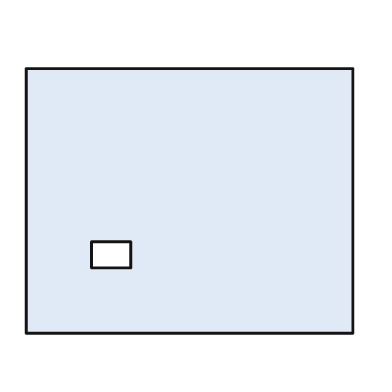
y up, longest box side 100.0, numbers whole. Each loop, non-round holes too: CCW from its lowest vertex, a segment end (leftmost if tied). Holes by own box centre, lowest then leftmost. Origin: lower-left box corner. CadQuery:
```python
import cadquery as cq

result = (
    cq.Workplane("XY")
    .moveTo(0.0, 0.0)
    .lineTo(100.0, 0.0)
    .lineTo(100.0, 81.0)
    .lineTo(0.0, 81.0)
    .close()
    .moveTo(20.0, 20.0)
    .lineTo(32.0, 20.0)
    .lineTo(32.0, 28.0)
    .lineTo(20.0, 28.0)
    .close()
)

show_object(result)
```